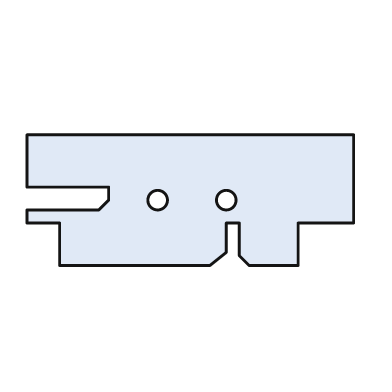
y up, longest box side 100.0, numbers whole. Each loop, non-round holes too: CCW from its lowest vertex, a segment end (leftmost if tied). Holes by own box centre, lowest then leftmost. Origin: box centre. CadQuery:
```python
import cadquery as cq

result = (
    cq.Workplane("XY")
    .moveTo(-40.0, -20.0)
    .lineTo(6.0, -20.0)
    .lineTo(11.0, -16.0)
    .lineTo(11.0, -7.0)
    .lineTo(15.0, -7.0)
    .lineTo(15.0, -17.0)
    .lineTo(18.0, -20.0)
    .lineTo(33.0, -20.0)
    .lineTo(33.0, -7.0)
    .lineTo(50.0, -7.0)
    .lineTo(50.0, 20.0)
    .lineTo(-50.0, 20.0)
    .lineTo(-50.0, 4.0)
    .lineTo(-25.0, 4.0)
    .lineTo(-25.0, 0.0)
    .lineTo(-28.0, -3.0)
    .lineTo(-50.0, -3.0)
    .lineTo(-50.0, -7.0)
    .lineTo(-40.0, -7.0)
    .close()
    .moveTo(-10.0, 0.0)
    .circle(3.0)
    .moveTo(11.0, 0.0)
    .circle(3.0)
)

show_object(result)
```